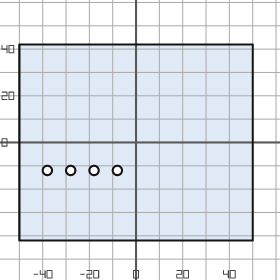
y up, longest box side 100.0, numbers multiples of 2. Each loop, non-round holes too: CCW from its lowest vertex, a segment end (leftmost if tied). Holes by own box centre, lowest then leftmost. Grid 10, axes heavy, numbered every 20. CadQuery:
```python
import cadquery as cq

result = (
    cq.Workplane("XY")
    .moveTo(-50.0, -42.0)
    .lineTo(50.0, -42.0)
    .lineTo(50.0, 42.0)
    .lineTo(-50.0, 42.0)
    .close()
    .moveTo(-38.0, -12.0)
    .circle(2.0)
    .moveTo(-28.0, -12.0)
    .circle(2.0)
    .moveTo(-18.0, -12.0)
    .circle(2.0)
    .moveTo(-8.0, -12.0)
    .circle(2.0)
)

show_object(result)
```